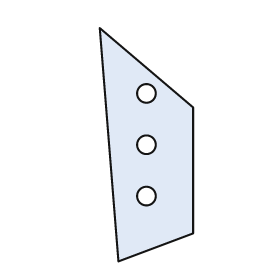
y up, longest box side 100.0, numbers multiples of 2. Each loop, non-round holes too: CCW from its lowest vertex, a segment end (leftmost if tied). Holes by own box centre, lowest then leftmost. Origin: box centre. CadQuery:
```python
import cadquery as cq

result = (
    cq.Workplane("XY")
    .moveTo(-12.0, -50.0)
    .lineTo(20.0, -38.0)
    .lineTo(20.0, 16.0)
    .lineTo(-20.0, 50.0)
    .close()
    .moveTo(0.0, -22.0)
    .circle(4.0)
    .moveTo(0.0, 0.0)
    .circle(4.0)
    .moveTo(0.0, 22.0)
    .circle(4.0)
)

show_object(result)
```